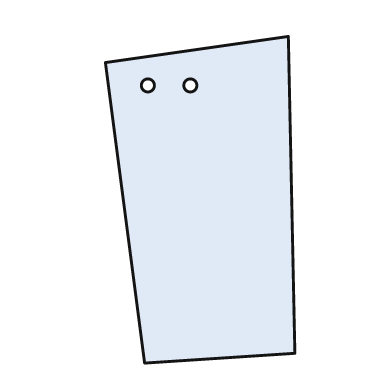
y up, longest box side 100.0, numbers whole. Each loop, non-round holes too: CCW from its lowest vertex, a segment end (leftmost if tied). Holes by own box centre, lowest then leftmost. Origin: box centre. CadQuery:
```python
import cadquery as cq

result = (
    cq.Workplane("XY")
    .moveTo(-17.0, -50.0)
    .lineTo(29.0, -47.0)
    .lineTo(27.0, 50.0)
    .lineTo(-29.0, 42.0)
    .close()
    .moveTo(-16.0, 35.0)
    .circle(2.0)
    .moveTo(-3.0, 35.0)
    .circle(2.0)
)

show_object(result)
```